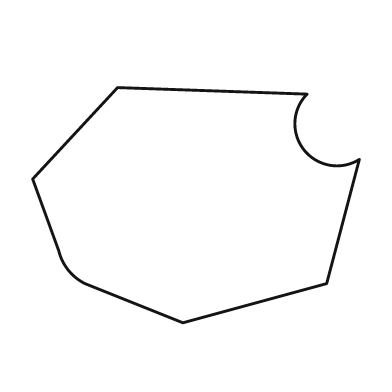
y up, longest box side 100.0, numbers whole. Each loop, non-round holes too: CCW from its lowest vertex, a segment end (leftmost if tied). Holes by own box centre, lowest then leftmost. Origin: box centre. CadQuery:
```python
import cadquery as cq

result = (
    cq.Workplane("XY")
    .moveTo(-4.0, -36.0)
    .lineTo(40.0, -24.0)
    .lineTo(50.0, 14.0)
    .threePointArc((33.0, 17.0), (34.0, 34.0))
    .lineTo(-24.0, 36.0)
    .lineTo(-50.0, 8.0)
    .lineTo(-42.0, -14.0)
    .threePointArc((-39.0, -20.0), (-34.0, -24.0))
    .close()
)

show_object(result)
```